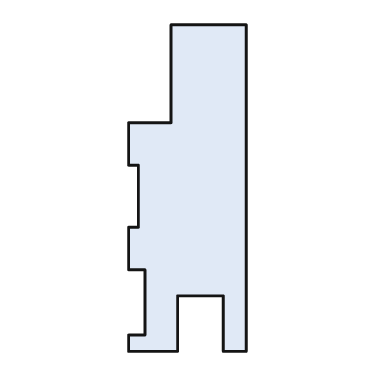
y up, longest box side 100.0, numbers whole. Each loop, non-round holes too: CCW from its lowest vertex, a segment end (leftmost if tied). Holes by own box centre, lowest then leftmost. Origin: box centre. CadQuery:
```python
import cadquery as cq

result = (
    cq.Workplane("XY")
    .moveTo(-18.0, -50.0)
    .lineTo(-3.0, -50.0)
    .lineTo(-3.0, -33.0)
    .lineTo(11.0, -33.0)
    .lineTo(11.0, -50.0)
    .lineTo(18.0, -50.0)
    .lineTo(18.0, 50.0)
    .lineTo(-5.0, 50.0)
    .lineTo(-5.0, 20.0)
    .lineTo(-18.0, 20.0)
    .lineTo(-18.0, 7.0)
    .lineTo(-15.0, 7.0)
    .lineTo(-15.0, -12.0)
    .lineTo(-18.0, -12.0)
    .lineTo(-18.0, -25.0)
    .lineTo(-13.0, -25.0)
    .lineTo(-13.0, -45.0)
    .lineTo(-18.0, -45.0)
    .close()
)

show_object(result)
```